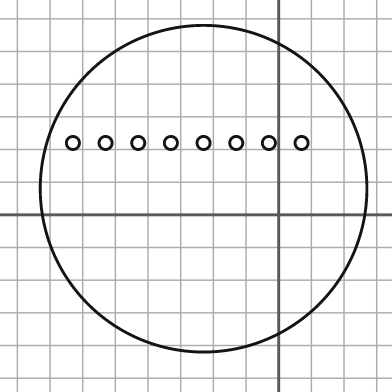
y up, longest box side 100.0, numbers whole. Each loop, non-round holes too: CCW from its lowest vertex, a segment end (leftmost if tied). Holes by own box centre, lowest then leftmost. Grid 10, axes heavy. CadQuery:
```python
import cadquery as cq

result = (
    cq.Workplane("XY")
    .moveTo(-23.0, 8.0)
    .circle(50.0)
    .moveTo(-63.0, 22.0)
    .circle(2.0)
    .moveTo(-53.0, 22.0)
    .circle(2.0)
    .moveTo(-43.0, 22.0)
    .circle(2.0)
    .moveTo(-33.0, 22.0)
    .circle(2.0)
    .moveTo(-23.0, 22.0)
    .circle(2.0)
    .moveTo(-13.0, 22.0)
    .circle(2.0)
    .moveTo(-3.0, 22.0)
    .circle(2.0)
    .moveTo(7.0, 22.0)
    .circle(2.0)
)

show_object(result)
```